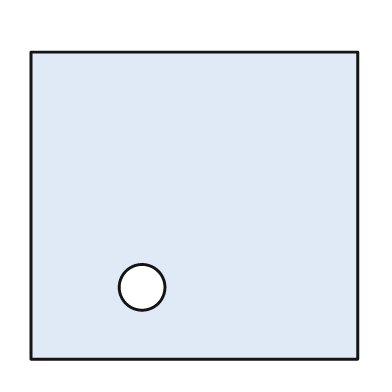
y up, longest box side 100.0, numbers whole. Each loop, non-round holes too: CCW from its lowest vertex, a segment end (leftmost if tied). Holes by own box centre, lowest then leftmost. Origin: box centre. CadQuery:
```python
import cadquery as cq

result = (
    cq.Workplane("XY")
    .moveTo(-50.0, -47.0)
    .lineTo(50.0, -47.0)
    .lineTo(50.0, 47.0)
    .lineTo(-50.0, 47.0)
    .close()
    .moveTo(-16.0, -25.0)
    .circle(7.0)
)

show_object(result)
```